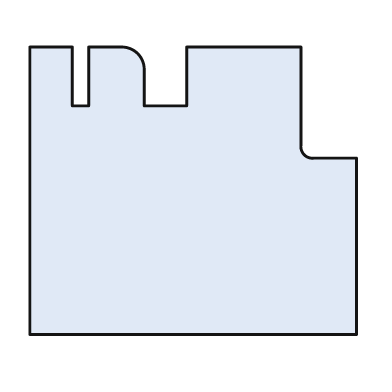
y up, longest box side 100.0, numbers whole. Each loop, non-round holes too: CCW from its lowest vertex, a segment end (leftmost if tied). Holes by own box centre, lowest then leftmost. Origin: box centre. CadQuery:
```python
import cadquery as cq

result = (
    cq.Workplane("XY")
    .moveTo(-50.0, -44.0)
    .lineTo(50.0, -44.0)
    .lineTo(50.0, 10.0)
    .lineTo(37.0, 10.0)
    .threePointArc((34.0, 11.0), (33.0, 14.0))
    .lineTo(33.0, 44.0)
    .lineTo(-2.0, 44.0)
    .lineTo(-2.0, 26.0)
    .lineTo(-15.0, 26.0)
    .lineTo(-15.0, 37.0)
    .threePointArc((-17.0, 42.0), (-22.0, 44.0))
    .lineTo(-32.0, 44.0)
    .lineTo(-32.0, 26.0)
    .lineTo(-37.0, 26.0)
    .lineTo(-37.0, 44.0)
    .lineTo(-50.0, 44.0)
    .close()
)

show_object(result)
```